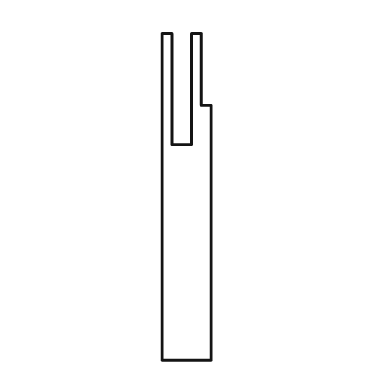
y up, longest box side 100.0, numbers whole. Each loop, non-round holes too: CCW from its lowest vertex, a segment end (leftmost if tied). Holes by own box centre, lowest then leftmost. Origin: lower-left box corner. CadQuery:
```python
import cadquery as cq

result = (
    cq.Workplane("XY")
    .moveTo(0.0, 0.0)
    .lineTo(15.0, 0.0)
    .lineTo(15.0, 78.0)
    .lineTo(12.0, 78.0)
    .lineTo(12.0, 100.0)
    .lineTo(9.0, 100.0)
    .lineTo(9.0, 66.0)
    .lineTo(3.0, 66.0)
    .lineTo(3.0, 100.0)
    .lineTo(0.0, 100.0)
    .close()
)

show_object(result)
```